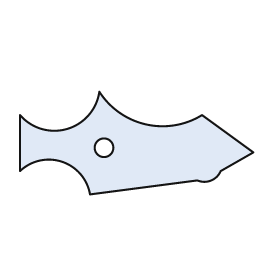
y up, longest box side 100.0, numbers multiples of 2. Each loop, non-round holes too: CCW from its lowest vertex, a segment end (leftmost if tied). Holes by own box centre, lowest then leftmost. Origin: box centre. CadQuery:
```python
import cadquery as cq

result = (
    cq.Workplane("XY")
    .moveTo(-20.0, -22.0)
    .lineTo(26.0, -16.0)
    .threePointArc((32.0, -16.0), (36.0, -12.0))
    .lineTo(50.0, -4.0)
    .lineTo(28.0, 12.0)
    .threePointArc((4.0, 8.0), (-16.0, 22.0))
    .threePointArc((-30.0, 6.0), (-50.0, 12.0))
    .lineTo(-50.0, -12.0)
    .threePointArc((-32.0, -8.0), (-20.0, -22.0))
    .close()
    .moveTo(-14.0, -2.0)
    .circle(4.0)
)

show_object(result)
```